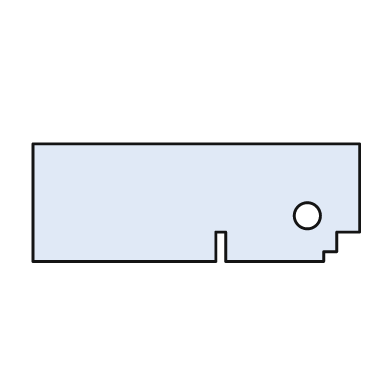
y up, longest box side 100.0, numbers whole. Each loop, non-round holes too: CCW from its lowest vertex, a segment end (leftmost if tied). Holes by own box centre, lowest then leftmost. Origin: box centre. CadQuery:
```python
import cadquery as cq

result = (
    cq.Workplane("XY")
    .moveTo(-50.0, -18.0)
    .lineTo(6.0, -18.0)
    .lineTo(6.0, -9.0)
    .lineTo(9.0, -9.0)
    .lineTo(9.0, -18.0)
    .lineTo(39.0, -18.0)
    .lineTo(39.0, -15.0)
    .lineTo(43.0, -15.0)
    .lineTo(43.0, -9.0)
    .lineTo(50.0, -9.0)
    .lineTo(50.0, 18.0)
    .lineTo(-50.0, 18.0)
    .close()
    .moveTo(34.0, -4.0)
    .circle(4.0)
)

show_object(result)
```